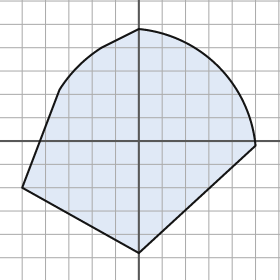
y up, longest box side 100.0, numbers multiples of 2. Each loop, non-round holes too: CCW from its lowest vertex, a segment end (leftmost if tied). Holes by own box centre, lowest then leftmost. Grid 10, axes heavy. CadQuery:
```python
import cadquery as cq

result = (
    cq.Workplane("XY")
    .moveTo(0.0, -48.0)
    .lineTo(50.0, -2.0)
    .threePointArc((34.0, 32.0), (0.0, 48.0))
    .lineTo(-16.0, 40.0)
    .threePointArc((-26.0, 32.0), (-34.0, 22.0))
    .lineTo(-50.0, -20.0)
    .close()
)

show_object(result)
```